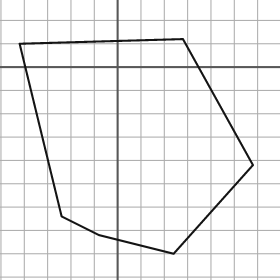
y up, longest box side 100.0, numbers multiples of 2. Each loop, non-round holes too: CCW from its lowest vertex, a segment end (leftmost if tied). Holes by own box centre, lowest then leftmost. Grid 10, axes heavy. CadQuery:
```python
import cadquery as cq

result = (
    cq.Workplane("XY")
    .moveTo(24.0, -80.0)
    .lineTo(58.0, -42.0)
    .lineTo(28.0, 12.0)
    .lineTo(-42.0, 10.0)
    .lineTo(-24.0, -64.0)
    .lineTo(-8.0, -72.0)
    .close()
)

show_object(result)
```